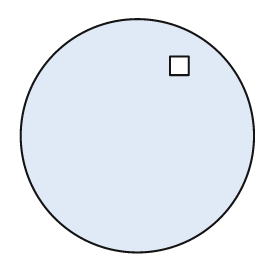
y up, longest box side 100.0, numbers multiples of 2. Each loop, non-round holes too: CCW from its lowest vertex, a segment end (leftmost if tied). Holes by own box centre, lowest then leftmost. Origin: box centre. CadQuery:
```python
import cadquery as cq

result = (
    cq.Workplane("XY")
    .moveTo(0.0, 0.0)
    .circle(50.0)
    .moveTo(14.0, 26.0)
    .lineTo(22.0, 26.0)
    .lineTo(22.0, 34.0)
    .lineTo(14.0, 34.0)
    .close()
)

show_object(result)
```